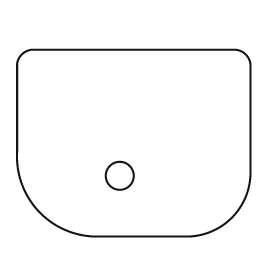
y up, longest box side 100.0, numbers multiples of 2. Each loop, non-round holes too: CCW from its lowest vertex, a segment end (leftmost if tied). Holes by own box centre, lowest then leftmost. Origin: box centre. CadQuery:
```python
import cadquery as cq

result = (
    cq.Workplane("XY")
    .moveTo(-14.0, -40.0)
    .lineTo(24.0, -40.0)
    .threePointArc((42.0, -32.0), (50.0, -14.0))
    .lineTo(50.0, 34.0)
    .threePointArc((48.0, 38.0), (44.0, 40.0))
    .lineTo(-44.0, 40.0)
    .threePointArc((-48.0, 38.0), (-50.0, 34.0))
    .lineTo(-50.0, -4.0)
    .threePointArc((-40.0, -30.0), (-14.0, -40.0))
    .close()
    .moveTo(-6.0, -14.0)
    .circle(6.0)
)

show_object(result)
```